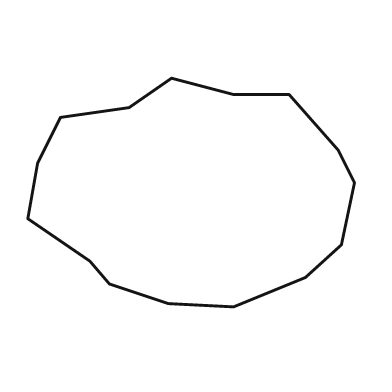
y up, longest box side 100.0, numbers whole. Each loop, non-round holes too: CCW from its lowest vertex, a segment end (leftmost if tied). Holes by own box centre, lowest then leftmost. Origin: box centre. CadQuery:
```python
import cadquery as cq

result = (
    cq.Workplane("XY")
    .moveTo(13.0, -35.0)
    .lineTo(35.0, -26.0)
    .lineTo(46.0, -16.0)
    .lineTo(50.0, 3.0)
    .lineTo(45.0, 13.0)
    .lineTo(30.0, 30.0)
    .lineTo(13.0, 30.0)
    .lineTo(-6.0, 35.0)
    .lineTo(-19.0, 26.0)
    .lineTo(-40.0, 23.0)
    .lineTo(-47.0, 9.0)
    .lineTo(-50.0, -8.0)
    .lineTo(-31.0, -21.0)
    .lineTo(-25.0, -28.0)
    .lineTo(-7.0, -34.0)
    .close()
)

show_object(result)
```